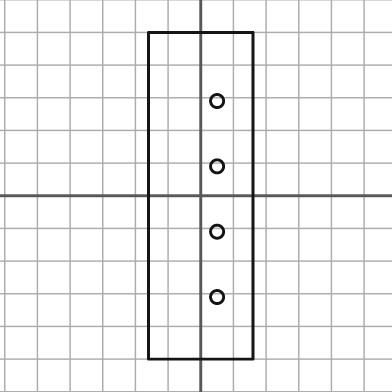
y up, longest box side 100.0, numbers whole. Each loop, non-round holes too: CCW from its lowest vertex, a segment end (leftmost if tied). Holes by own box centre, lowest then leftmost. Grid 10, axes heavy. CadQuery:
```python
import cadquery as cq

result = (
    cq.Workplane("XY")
    .moveTo(-16.0, -50.0)
    .lineTo(16.0, -50.0)
    .lineTo(16.0, 50.0)
    .lineTo(-16.0, 50.0)
    .close()
    .moveTo(5.0, -31.0)
    .circle(2.0)
    .moveTo(5.0, -11.0)
    .circle(2.0)
    .moveTo(5.0, 9.0)
    .circle(2.0)
    .moveTo(5.0, 29.0)
    .circle(2.0)
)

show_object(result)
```